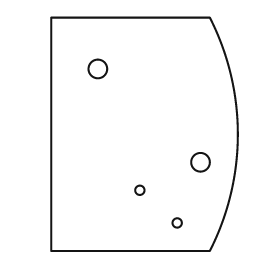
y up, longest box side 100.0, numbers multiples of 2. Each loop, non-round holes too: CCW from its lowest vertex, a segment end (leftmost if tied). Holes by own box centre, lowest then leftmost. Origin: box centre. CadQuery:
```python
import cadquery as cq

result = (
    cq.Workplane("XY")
    .moveTo(-40.0, -50.0)
    .lineTo(28.0, -50.0)
    .threePointArc((40.0, 0.0), (28.0, 50.0))
    .lineTo(-40.0, 50.0)
    .close()
    .moveTo(14.0, -38.0)
    .circle(2.0)
    .moveTo(-2.0, -24.0)
    .circle(2.0)
    .moveTo(24.0, -12.0)
    .circle(4.0)
    .moveTo(-20.0, 28.0)
    .circle(4.0)
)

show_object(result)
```